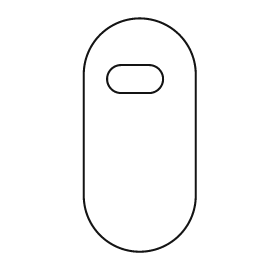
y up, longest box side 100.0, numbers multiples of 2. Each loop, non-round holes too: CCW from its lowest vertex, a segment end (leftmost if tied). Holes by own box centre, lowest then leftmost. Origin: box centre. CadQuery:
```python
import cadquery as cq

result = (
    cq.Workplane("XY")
    .moveTo(-24.0, -26.0)
    .threePointArc((0.0, -50.0), (24.0, -26.0))
    .lineTo(24.0, 26.0)
    .threePointArc((0.0, 50.0), (-24.0, 26.0))
    .close()
    .moveTo(-8.0, 18.0)
    .lineTo(4.0, 18.0)
    .threePointArc((10.0, 24.0), (4.0, 30.0))
    .lineTo(-8.0, 30.0)
    .threePointArc((-14.0, 24.0), (-8.0, 18.0))
    .close()
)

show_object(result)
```